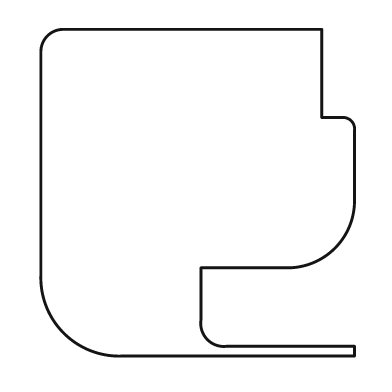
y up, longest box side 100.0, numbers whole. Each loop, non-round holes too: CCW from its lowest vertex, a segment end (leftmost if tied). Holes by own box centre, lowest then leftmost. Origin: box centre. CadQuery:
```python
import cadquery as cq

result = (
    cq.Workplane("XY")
    .moveTo(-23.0, -50.0)
    .lineTo(48.0, -50.0)
    .lineTo(48.0, -47.0)
    .lineTo(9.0, -47.0)
    .threePointArc((3.0, -45.0), (1.0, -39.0))
    .lineTo(1.0, -23.0)
    .lineTo(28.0, -23.0)
    .threePointArc((42.0, -17.0), (48.0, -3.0))
    .lineTo(48.0, 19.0)
    .threePointArc((47.0, 22.0), (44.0, 23.0))
    .lineTo(38.0, 23.0)
    .lineTo(38.0, 50.0)
    .lineTo(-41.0, 50.0)
    .threePointArc((-46.0, 48.0), (-48.0, 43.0))
    .lineTo(-48.0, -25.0)
    .threePointArc((-41.0, -43.0), (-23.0, -50.0))
    .close()
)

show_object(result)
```